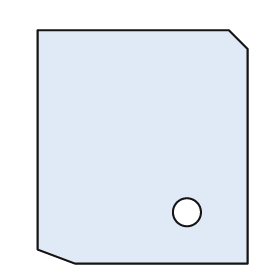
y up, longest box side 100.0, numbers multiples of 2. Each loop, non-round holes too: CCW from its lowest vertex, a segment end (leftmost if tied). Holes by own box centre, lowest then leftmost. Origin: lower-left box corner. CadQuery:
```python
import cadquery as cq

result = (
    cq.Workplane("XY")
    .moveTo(16.0, 0.0)
    .lineTo(90.0, 0.0)
    .lineTo(90.0, 92.0)
    .lineTo(82.0, 100.0)
    .lineTo(0.0, 100.0)
    .lineTo(0.0, 6.0)
    .close()
    .moveTo(64.0, 22.0)
    .circle(6.0)
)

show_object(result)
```